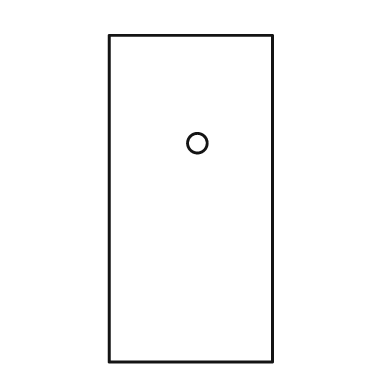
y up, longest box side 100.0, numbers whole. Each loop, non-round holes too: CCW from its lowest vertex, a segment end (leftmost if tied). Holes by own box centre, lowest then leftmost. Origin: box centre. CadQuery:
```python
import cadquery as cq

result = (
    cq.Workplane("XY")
    .moveTo(-25.0, -50.0)
    .lineTo(25.0, -50.0)
    .lineTo(25.0, 50.0)
    .lineTo(-25.0, 50.0)
    .close()
    .moveTo(2.0, 17.0)
    .circle(3.0)
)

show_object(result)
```